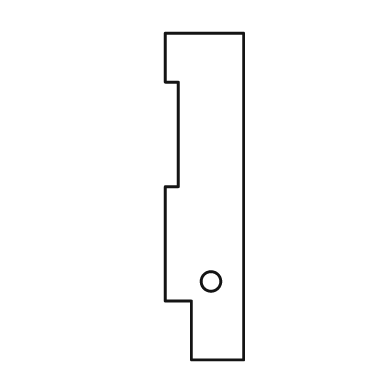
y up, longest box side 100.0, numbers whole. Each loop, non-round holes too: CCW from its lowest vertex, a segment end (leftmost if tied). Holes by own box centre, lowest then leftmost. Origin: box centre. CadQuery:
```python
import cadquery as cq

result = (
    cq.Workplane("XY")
    .moveTo(-4.0, -50.0)
    .lineTo(12.0, -50.0)
    .lineTo(12.0, 50.0)
    .lineTo(-12.0, 50.0)
    .lineTo(-12.0, 35.0)
    .lineTo(-8.0, 35.0)
    .lineTo(-8.0, 3.0)
    .lineTo(-12.0, 3.0)
    .lineTo(-12.0, -32.0)
    .lineTo(-4.0, -32.0)
    .close()
    .moveTo(2.0, -26.0)
    .circle(3.0)
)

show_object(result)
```